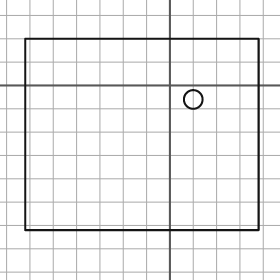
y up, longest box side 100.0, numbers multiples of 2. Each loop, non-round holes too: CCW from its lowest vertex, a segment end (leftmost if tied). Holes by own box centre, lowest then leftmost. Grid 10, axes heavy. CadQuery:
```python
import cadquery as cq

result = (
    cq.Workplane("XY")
    .moveTo(-62.0, -62.0)
    .lineTo(38.0, -62.0)
    .lineTo(38.0, 20.0)
    .lineTo(-62.0, 20.0)
    .close()
    .moveTo(10.0, -6.0)
    .circle(4.0)
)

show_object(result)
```